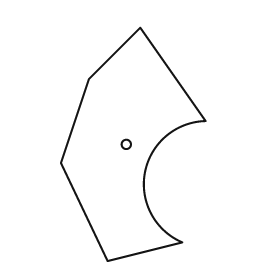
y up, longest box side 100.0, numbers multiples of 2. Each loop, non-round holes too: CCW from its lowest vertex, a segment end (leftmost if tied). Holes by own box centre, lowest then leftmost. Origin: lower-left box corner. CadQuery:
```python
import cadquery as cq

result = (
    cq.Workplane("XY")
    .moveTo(20.0, 0.0)
    .lineTo(52.0, 8.0)
    .threePointArc((36.0, 38.0), (62.0, 60.0))
    .lineTo(34.0, 100.0)
    .lineTo(12.0, 78.0)
    .lineTo(0.0, 42.0)
    .close()
    .moveTo(28.0, 50.0)
    .circle(2.0)
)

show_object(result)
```